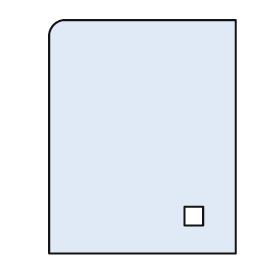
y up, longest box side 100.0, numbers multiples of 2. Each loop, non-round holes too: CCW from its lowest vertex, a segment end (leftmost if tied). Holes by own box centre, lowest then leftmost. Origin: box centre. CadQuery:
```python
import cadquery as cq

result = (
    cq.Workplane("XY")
    .moveTo(-40.0, -50.0)
    .lineTo(40.0, -50.0)
    .lineTo(40.0, 50.0)
    .lineTo(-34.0, 50.0)
    .threePointArc((-38.0, 48.0), (-40.0, 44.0))
    .close()
    .moveTo(18.0, -38.0)
    .lineTo(26.0, -38.0)
    .lineTo(26.0, -30.0)
    .lineTo(18.0, -30.0)
    .close()
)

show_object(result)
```